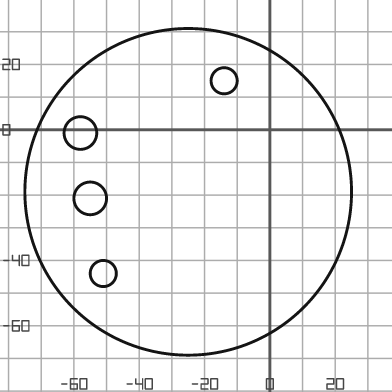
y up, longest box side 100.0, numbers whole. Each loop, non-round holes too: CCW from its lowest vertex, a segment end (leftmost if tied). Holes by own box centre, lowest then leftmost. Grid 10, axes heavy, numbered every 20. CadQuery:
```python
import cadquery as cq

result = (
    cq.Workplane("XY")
    .moveTo(-25.0, -19.0)
    .circle(50.0)
    .moveTo(-51.0, -44.0)
    .circle(4.0)
    .moveTo(-55.0, -21.0)
    .circle(5.0)
    .moveTo(-58.0, -1.0)
    .circle(5.0)
    .moveTo(-14.0, 15.0)
    .circle(4.0)
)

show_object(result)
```